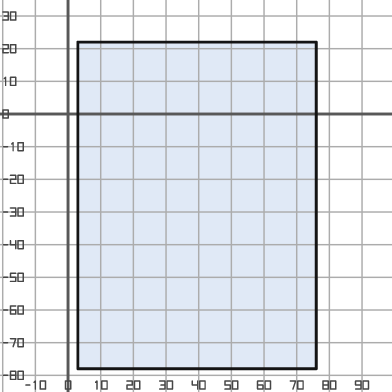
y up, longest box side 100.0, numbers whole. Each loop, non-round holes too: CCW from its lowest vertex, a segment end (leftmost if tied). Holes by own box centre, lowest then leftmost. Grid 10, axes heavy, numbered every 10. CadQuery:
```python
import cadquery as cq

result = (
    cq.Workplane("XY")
    .moveTo(3.0, -78.0)
    .lineTo(76.0, -78.0)
    .lineTo(76.0, 22.0)
    .lineTo(3.0, 22.0)
    .close()
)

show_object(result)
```